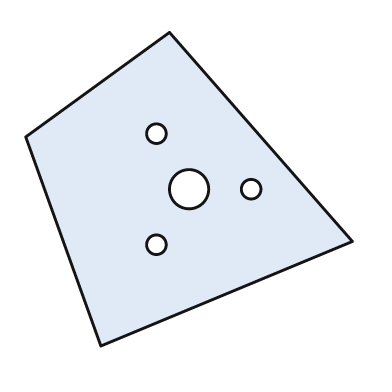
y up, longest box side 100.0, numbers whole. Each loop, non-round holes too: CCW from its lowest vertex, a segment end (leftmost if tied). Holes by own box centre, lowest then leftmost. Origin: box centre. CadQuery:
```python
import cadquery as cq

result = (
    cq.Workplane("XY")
    .moveTo(-27.0, -48.0)
    .lineTo(50.0, -16.0)
    .lineTo(-6.0, 48.0)
    .lineTo(-50.0, 16.0)
    .close()
    .moveTo(-10.0, -17.0)
    .circle(3.0)
    .moveTo(0.0, 0.0)
    .circle(6.0)
    .moveTo(19.0, 0.0)
    .circle(3.0)
    .moveTo(-10.0, 17.0)
    .circle(3.0)
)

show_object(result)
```